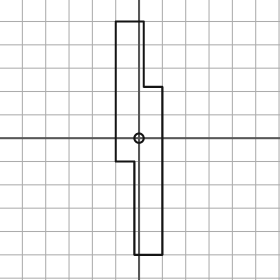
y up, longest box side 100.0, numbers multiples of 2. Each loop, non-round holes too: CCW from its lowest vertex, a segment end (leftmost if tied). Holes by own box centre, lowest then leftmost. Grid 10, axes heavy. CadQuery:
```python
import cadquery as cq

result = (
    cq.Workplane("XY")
    .moveTo(-2.0, -50.0)
    .lineTo(10.0, -50.0)
    .lineTo(10.0, 22.0)
    .lineTo(2.0, 22.0)
    .lineTo(2.0, 50.0)
    .lineTo(-10.0, 50.0)
    .lineTo(-10.0, -10.0)
    .lineTo(-2.0, -10.0)
    .close()
    .moveTo(0.0, 0.0)
    .circle(2.0)
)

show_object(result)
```